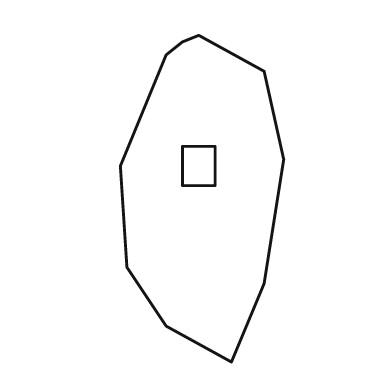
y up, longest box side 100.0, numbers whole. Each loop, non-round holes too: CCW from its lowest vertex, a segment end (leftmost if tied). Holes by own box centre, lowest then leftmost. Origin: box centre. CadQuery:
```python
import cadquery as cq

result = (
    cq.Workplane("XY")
    .moveTo(9.0, -50.0)
    .lineTo(19.0, -26.0)
    .lineTo(25.0, 12.0)
    .lineTo(19.0, 39.0)
    .lineTo(-1.0, 50.0)
    .lineTo(-6.0, 48.0)
    .lineTo(-11.0, 44.0)
    .lineTo(-25.0, 10.0)
    .lineTo(-23.0, -21.0)
    .lineTo(-11.0, -39.0)
    .close()
    .moveTo(-6.0, 4.0)
    .lineTo(4.0, 4.0)
    .lineTo(4.0, 16.0)
    .lineTo(-6.0, 16.0)
    .close()
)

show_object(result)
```